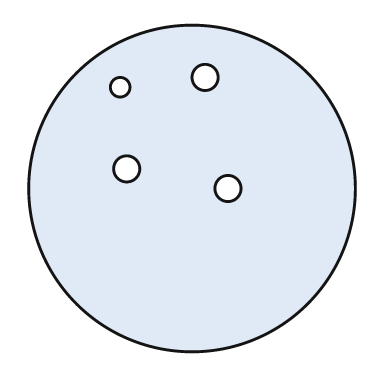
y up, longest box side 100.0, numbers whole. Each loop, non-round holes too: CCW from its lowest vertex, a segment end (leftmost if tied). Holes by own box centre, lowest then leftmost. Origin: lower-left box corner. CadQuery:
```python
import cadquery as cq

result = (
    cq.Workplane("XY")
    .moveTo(50.0, 50.0)
    .circle(50.0)
    .moveTo(61.0, 50.0)
    .circle(4.0)
    .moveTo(30.0, 56.0)
    .circle(4.0)
    .moveTo(28.0, 81.0)
    .circle(3.0)
    .moveTo(54.0, 84.0)
    .circle(4.0)
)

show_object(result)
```